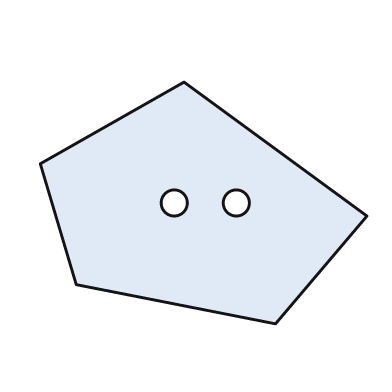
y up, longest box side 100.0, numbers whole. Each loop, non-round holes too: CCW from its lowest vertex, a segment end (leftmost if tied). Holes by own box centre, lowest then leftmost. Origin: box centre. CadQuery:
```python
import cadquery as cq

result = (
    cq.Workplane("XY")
    .moveTo(22.0, -37.0)
    .lineTo(50.0, -4.0)
    .lineTo(-6.0, 37.0)
    .lineTo(-50.0, 12.0)
    .lineTo(-39.0, -25.0)
    .close()
    .moveTo(-9.0, 0.0)
    .circle(4.0)
    .moveTo(10.0, 0.0)
    .circle(4.0)
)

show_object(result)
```